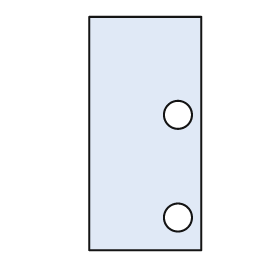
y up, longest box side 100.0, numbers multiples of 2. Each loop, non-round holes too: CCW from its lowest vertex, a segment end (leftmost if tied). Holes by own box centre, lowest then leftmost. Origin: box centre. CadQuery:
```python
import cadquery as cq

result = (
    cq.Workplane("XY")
    .moveTo(-24.0, -50.0)
    .lineTo(24.0, -50.0)
    .lineTo(24.0, 50.0)
    .lineTo(-24.0, 50.0)
    .close()
    .moveTo(14.0, -36.0)
    .circle(6.0)
    .moveTo(14.0, 8.0)
    .circle(6.0)
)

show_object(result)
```